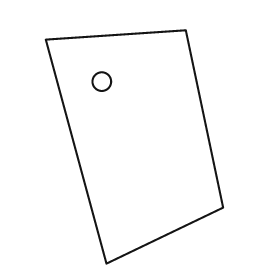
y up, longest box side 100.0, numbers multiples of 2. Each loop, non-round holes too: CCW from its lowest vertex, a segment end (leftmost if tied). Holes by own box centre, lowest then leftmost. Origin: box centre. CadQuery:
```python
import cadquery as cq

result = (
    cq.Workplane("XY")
    .moveTo(-12.0, -50.0)
    .lineTo(38.0, -26.0)
    .lineTo(22.0, 50.0)
    .lineTo(-38.0, 46.0)
    .close()
    .moveTo(-14.0, 28.0)
    .circle(4.0)
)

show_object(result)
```